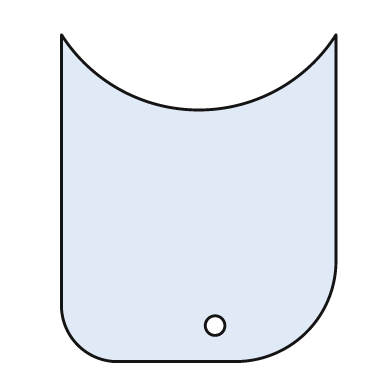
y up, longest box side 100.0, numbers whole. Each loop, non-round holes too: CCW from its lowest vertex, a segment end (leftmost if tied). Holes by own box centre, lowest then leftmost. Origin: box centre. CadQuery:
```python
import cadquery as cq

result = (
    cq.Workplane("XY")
    .moveTo(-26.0, -50.0)
    .lineTo(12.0, -50.0)
    .threePointArc((33.0, -41.0), (42.0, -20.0))
    .lineTo(42.0, 50.0)
    .threePointArc((0.0, 27.0), (-42.0, 50.0))
    .lineTo(-42.0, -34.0)
    .threePointArc((-37.0, -45.0), (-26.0, -50.0))
    .close()
    .moveTo(5.0, -39.0)
    .circle(3.0)
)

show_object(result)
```